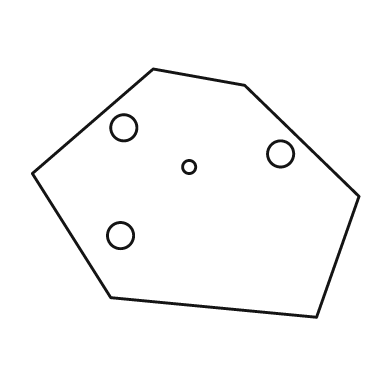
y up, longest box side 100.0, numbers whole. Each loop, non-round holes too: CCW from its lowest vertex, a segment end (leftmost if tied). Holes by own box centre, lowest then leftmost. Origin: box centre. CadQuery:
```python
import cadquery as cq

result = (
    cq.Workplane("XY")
    .moveTo(37.0, -38.0)
    .lineTo(50.0, -1.0)
    .lineTo(15.0, 33.0)
    .lineTo(-13.0, 38.0)
    .lineTo(-50.0, 6.0)
    .lineTo(-26.0, -32.0)
    .close()
    .moveTo(-23.0, -13.0)
    .circle(4.0)
    .moveTo(-2.0, 8.0)
    .circle(2.0)
    .moveTo(26.0, 12.0)
    .circle(4.0)
    .moveTo(-22.0, 20.0)
    .circle(4.0)
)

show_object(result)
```